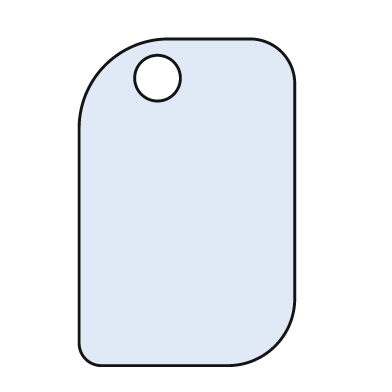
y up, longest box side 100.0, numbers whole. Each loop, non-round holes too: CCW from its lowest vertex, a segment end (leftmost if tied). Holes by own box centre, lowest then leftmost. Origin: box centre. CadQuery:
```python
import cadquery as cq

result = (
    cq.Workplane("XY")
    .moveTo(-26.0, -50.0)
    .lineTo(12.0, -50.0)
    .threePointArc((27.0, -44.0), (33.0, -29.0))
    .lineTo(33.0, 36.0)
    .threePointArc((29.0, 46.0), (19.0, 50.0))
    .lineTo(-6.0, 50.0)
    .threePointArc((-25.0, 42.0), (-33.0, 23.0))
    .lineTo(-33.0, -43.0)
    .threePointArc((-31.0, -48.0), (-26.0, -50.0))
    .close()
    .moveTo(-9.0, 38.0)
    .circle(7.0)
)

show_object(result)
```